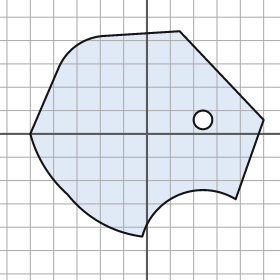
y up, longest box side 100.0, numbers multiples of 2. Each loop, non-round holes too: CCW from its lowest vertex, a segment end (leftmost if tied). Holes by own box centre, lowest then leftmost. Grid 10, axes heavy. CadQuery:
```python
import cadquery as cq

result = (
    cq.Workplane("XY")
    .moveTo(-2.0, -44.0)
    .threePointArc((14.0, -26.0), (38.0, -28.0))
    .lineTo(50.0, 6.0)
    .lineTo(14.0, 44.0)
    .lineTo(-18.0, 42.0)
    .threePointArc((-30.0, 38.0), (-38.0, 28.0))
    .lineTo(-50.0, 0.0)
    .threePointArc((-44.0, -14.0), (-34.0, -26.0))
    .threePointArc((-20.0, -38.0), (-2.0, -44.0))
    .close()
    .moveTo(24.0, 6.0)
    .circle(4.0)
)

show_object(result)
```